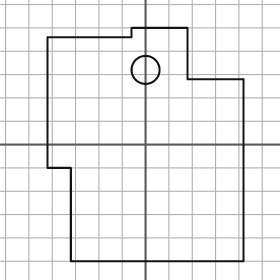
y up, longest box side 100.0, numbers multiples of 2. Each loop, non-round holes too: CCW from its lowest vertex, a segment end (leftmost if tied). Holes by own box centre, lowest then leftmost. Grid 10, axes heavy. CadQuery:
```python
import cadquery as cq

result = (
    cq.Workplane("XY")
    .moveTo(-32.0, -50.0)
    .lineTo(42.0, -50.0)
    .lineTo(42.0, 28.0)
    .lineTo(18.0, 28.0)
    .lineTo(18.0, 50.0)
    .lineTo(-6.0, 50.0)
    .lineTo(-6.0, 46.0)
    .lineTo(-42.0, 46.0)
    .lineTo(-42.0, -10.0)
    .lineTo(-32.0, -10.0)
    .close()
    .moveTo(0.0, 32.0)
    .circle(6.0)
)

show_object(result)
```